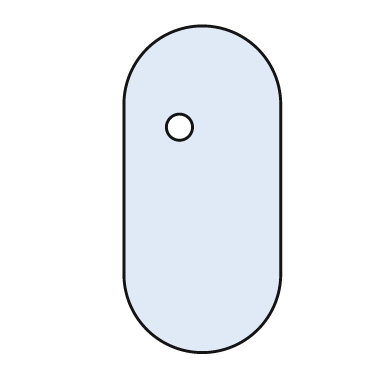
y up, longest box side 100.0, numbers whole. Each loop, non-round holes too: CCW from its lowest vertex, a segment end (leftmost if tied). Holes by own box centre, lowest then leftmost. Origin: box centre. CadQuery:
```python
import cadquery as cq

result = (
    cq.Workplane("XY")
    .moveTo(-24.0, -26.0)
    .threePointArc((0.0, -50.0), (24.0, -26.0))
    .lineTo(24.0, 26.0)
    .threePointArc((0.0, 50.0), (-24.0, 26.0))
    .close()
    .moveTo(-7.0, 19.0)
    .circle(4.0)
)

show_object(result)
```